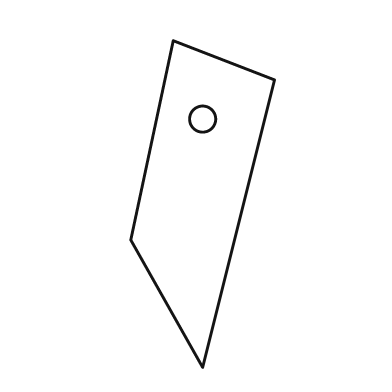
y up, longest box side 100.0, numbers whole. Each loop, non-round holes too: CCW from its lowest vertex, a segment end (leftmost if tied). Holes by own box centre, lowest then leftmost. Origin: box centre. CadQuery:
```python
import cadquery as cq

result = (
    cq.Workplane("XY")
    .moveTo(0.0, -50.0)
    .lineTo(22.0, 38.0)
    .lineTo(-9.0, 50.0)
    .lineTo(-22.0, -11.0)
    .close()
    .moveTo(0.0, 26.0)
    .circle(4.0)
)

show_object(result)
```